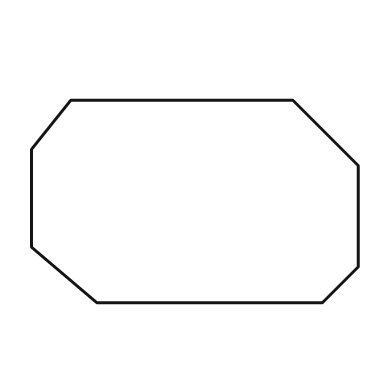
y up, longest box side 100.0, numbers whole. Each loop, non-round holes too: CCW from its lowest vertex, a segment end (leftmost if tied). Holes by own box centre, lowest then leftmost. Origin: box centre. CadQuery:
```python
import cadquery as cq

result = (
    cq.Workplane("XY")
    .moveTo(-30.0, -31.0)
    .lineTo(39.0, -31.0)
    .lineTo(50.0, -20.0)
    .lineTo(50.0, 11.0)
    .lineTo(30.0, 31.0)
    .lineTo(-38.0, 31.0)
    .lineTo(-50.0, 16.0)
    .lineTo(-50.0, -14.0)
    .close()
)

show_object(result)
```